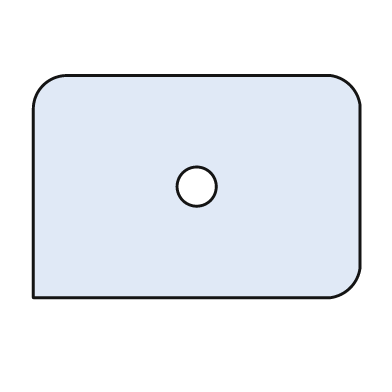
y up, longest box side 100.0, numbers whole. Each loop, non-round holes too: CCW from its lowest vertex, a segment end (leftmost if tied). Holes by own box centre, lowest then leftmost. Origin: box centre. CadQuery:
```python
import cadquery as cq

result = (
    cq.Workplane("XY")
    .moveTo(-50.0, -34.0)
    .lineTo(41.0, -34.0)
    .threePointArc((47.0, -31.0), (50.0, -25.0))
    .lineTo(50.0, 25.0)
    .threePointArc((47.0, 31.0), (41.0, 34.0))
    .lineTo(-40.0, 34.0)
    .threePointArc((-47.0, 31.0), (-50.0, 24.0))
    .close()
    .moveTo(0.0, 0.0)
    .circle(6.0)
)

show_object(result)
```